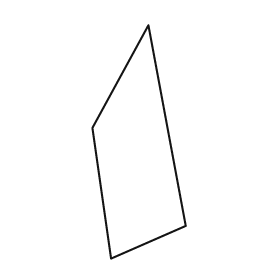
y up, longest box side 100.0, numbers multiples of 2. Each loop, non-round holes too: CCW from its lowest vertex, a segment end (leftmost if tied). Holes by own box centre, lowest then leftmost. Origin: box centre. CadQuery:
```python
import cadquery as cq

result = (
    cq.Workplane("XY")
    .moveTo(-12.0, -50.0)
    .lineTo(20.0, -36.0)
    .lineTo(4.0, 50.0)
    .lineTo(-20.0, 6.0)
    .close()
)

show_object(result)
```